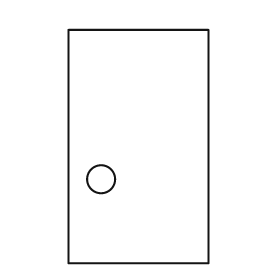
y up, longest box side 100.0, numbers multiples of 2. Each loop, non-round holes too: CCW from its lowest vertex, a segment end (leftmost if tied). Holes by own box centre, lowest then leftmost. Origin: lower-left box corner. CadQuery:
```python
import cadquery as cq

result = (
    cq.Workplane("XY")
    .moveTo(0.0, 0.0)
    .lineTo(60.0, 0.0)
    .lineTo(60.0, 100.0)
    .lineTo(0.0, 100.0)
    .close()
    .moveTo(14.0, 36.0)
    .circle(6.0)
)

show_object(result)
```